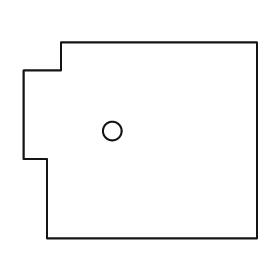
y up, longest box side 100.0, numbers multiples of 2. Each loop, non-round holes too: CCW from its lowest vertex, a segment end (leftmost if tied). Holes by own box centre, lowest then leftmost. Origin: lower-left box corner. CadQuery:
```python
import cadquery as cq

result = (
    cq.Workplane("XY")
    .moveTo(10.0, 0.0)
    .lineTo(100.0, 0.0)
    .lineTo(100.0, 84.0)
    .lineTo(16.0, 84.0)
    .lineTo(16.0, 72.0)
    .lineTo(0.0, 72.0)
    .lineTo(0.0, 34.0)
    .lineTo(10.0, 34.0)
    .close()
    .moveTo(38.0, 46.0)
    .circle(4.0)
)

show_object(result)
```